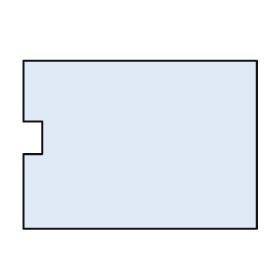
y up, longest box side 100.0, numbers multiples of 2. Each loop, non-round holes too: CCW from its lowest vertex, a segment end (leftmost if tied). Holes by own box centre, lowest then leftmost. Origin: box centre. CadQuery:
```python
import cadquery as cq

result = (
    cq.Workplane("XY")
    .moveTo(-50.0, -36.0)
    .lineTo(50.0, -36.0)
    .lineTo(50.0, 36.0)
    .lineTo(-50.0, 36.0)
    .lineTo(-50.0, 10.0)
    .lineTo(-42.0, 10.0)
    .lineTo(-42.0, -4.0)
    .lineTo(-50.0, -4.0)
    .close()
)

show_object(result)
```